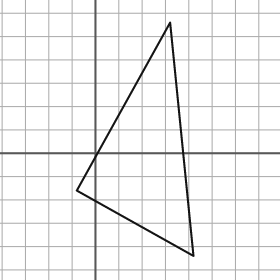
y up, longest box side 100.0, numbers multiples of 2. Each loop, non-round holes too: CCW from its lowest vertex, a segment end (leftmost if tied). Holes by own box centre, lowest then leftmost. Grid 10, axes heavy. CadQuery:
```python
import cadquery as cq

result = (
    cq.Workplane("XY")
    .moveTo(42.0, -44.0)
    .lineTo(32.0, 56.0)
    .lineTo(-8.0, -16.0)
    .close()
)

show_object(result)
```